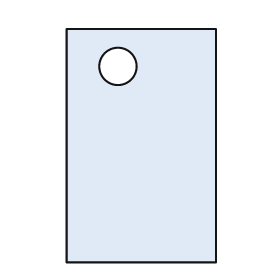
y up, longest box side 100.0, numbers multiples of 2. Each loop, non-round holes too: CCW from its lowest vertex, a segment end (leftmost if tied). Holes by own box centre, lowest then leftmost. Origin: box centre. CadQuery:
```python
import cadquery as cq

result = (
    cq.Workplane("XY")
    .moveTo(-32.0, -50.0)
    .lineTo(32.0, -50.0)
    .lineTo(32.0, 50.0)
    .lineTo(-32.0, 50.0)
    .close()
    .moveTo(-10.0, 34.0)
    .circle(8.0)
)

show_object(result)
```